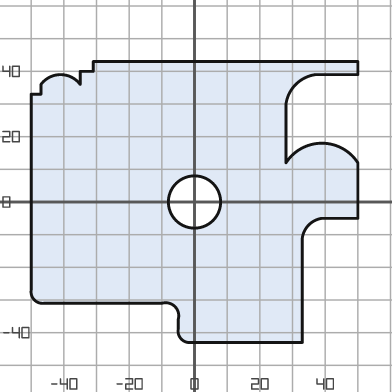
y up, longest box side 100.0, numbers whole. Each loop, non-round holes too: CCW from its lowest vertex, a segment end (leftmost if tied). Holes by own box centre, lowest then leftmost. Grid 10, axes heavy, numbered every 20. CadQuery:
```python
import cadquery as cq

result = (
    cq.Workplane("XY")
    .moveTo(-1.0, -43.0)
    .lineTo(33.0, -43.0)
    .lineTo(33.0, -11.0)
    .threePointArc((35.0, -7.0), (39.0, -5.0))
    .lineTo(50.0, -5.0)
    .lineTo(50.0, 12.0)
    .threePointArc((39.0, 18.0), (28.0, 12.0))
    .lineTo(28.0, 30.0)
    .threePointArc((31.0, 36.0), (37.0, 39.0))
    .lineTo(50.0, 39.0)
    .lineTo(50.0, 43.0)
    .lineTo(-31.0, 43.0)
    .lineTo(-31.0, 40.0)
    .lineTo(-35.0, 40.0)
    .lineTo(-35.0, 36.0)
    .threePointArc((-41.0, 39.0), (-47.0, 36.0))
    .lineTo(-47.0, 33.0)
    .lineTo(-50.0, 33.0)
    .lineTo(-50.0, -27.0)
    .threePointArc((-49.0, -30.0), (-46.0, -31.0))
    .lineTo(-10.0, -31.0)
    .threePointArc((-6.0, -32.0), (-5.0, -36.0))
    .lineTo(-5.0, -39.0)
    .threePointArc((-4.0, -42.0), (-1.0, -43.0))
    .close()
    .moveTo(0.0, 0.0)
    .circle(8.0)
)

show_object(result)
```